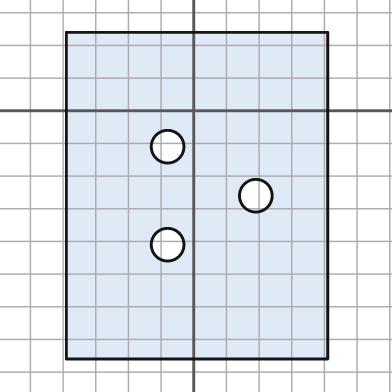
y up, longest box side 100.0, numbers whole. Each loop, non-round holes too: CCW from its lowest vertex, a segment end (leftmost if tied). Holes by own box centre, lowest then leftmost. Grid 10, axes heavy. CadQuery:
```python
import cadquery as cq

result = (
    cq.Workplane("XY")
    .moveTo(-39.0, -76.0)
    .lineTo(41.0, -76.0)
    .lineTo(41.0, 24.0)
    .lineTo(-39.0, 24.0)
    .close()
    .moveTo(-8.0, -41.0)
    .circle(5.0)
    .moveTo(19.0, -26.0)
    .circle(5.0)
    .moveTo(-8.0, -11.0)
    .circle(5.0)
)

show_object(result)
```